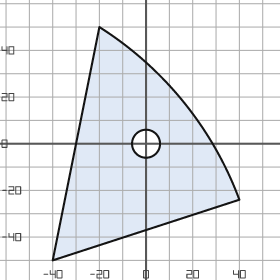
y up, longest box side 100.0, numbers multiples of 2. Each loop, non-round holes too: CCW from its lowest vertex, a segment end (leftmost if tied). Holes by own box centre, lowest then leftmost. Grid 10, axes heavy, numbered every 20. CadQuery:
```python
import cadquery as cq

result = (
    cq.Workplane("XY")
    .moveTo(-40.0, -50.0)
    .lineTo(40.0, -24.0)
    .threePointArc((16.0, 18.0), (-20.0, 50.0))
    .close()
    .moveTo(0.0, 0.0)
    .circle(6.0)
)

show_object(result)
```